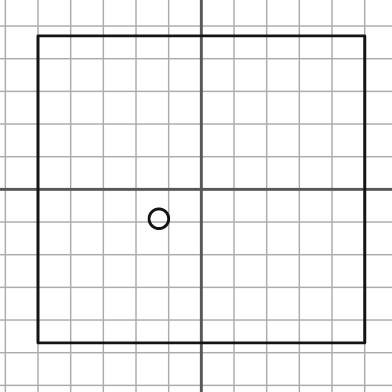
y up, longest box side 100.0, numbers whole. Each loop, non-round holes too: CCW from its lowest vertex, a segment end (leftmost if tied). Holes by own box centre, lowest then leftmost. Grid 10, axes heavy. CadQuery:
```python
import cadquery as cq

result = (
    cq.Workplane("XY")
    .moveTo(-50.0, -47.0)
    .lineTo(50.0, -47.0)
    .lineTo(50.0, 47.0)
    .lineTo(-50.0, 47.0)
    .close()
    .moveTo(-13.0, -9.0)
    .circle(3.0)
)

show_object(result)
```